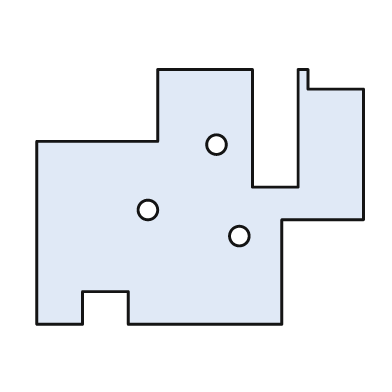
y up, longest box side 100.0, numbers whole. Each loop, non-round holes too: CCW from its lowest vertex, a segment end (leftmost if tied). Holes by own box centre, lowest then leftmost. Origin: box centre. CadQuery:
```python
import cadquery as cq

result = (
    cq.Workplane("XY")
    .moveTo(-50.0, -39.0)
    .lineTo(-36.0, -39.0)
    .lineTo(-36.0, -29.0)
    .lineTo(-22.0, -29.0)
    .lineTo(-22.0, -39.0)
    .lineTo(25.0, -39.0)
    .lineTo(25.0, -7.0)
    .lineTo(50.0, -7.0)
    .lineTo(50.0, 33.0)
    .lineTo(33.0, 33.0)
    .lineTo(33.0, 39.0)
    .lineTo(30.0, 39.0)
    .lineTo(30.0, 3.0)
    .lineTo(16.0, 3.0)
    .lineTo(16.0, 39.0)
    .lineTo(-13.0, 39.0)
    .lineTo(-13.0, 17.0)
    .lineTo(-50.0, 17.0)
    .close()
    .moveTo(12.0, -12.0)
    .circle(3.0)
    .moveTo(-16.0, -4.0)
    .circle(3.0)
    .moveTo(5.0, 16.0)
    .circle(3.0)
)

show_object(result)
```